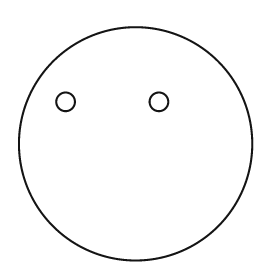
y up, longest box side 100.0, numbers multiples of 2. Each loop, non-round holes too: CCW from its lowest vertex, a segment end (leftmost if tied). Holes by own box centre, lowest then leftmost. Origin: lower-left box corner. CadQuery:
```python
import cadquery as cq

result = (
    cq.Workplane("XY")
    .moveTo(50.0, 50.0)
    .circle(50.0)
    .moveTo(20.0, 68.0)
    .circle(4.0)
    .moveTo(60.0, 68.0)
    .circle(4.0)
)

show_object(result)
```